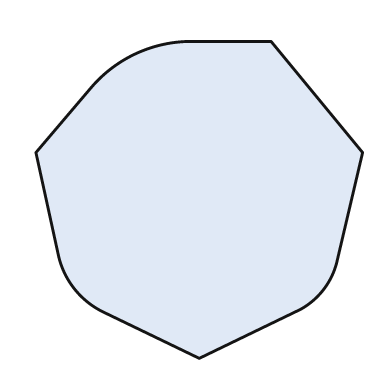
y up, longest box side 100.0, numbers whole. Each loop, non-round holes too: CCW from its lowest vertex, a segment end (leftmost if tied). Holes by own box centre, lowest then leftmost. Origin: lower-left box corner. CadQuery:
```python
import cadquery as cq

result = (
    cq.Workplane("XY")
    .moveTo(50.0, 0.0)
    .lineTo(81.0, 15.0)
    .threePointArc((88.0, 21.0), (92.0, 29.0))
    .lineTo(100.0, 63.0)
    .lineTo(72.0, 97.0)
    .lineTo(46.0, 97.0)
    .threePointArc((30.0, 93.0), (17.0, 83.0))
    .lineTo(0.0, 63.0)
    .lineTo(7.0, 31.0)
    .threePointArc((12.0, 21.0), (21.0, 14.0))
    .close()
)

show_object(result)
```